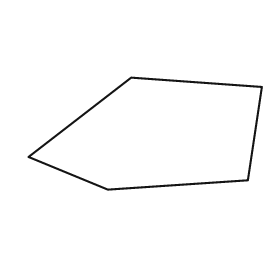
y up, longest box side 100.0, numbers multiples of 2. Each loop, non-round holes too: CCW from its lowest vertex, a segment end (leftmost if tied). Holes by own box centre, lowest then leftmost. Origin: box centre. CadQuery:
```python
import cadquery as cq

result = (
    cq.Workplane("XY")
    .moveTo(-16.0, -24.0)
    .lineTo(44.0, -20.0)
    .lineTo(50.0, 20.0)
    .lineTo(-6.0, 24.0)
    .lineTo(-50.0, -10.0)
    .close()
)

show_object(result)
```